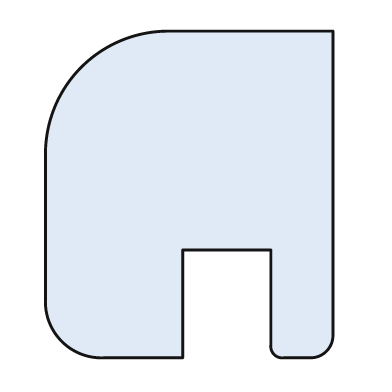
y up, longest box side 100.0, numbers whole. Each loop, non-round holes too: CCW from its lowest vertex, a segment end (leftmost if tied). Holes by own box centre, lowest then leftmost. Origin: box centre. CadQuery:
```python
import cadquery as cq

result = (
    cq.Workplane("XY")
    .moveTo(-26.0, -50.0)
    .lineTo(-2.0, -50.0)
    .lineTo(-2.0, -17.0)
    .lineTo(25.0, -17.0)
    .lineTo(25.0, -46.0)
    .threePointArc((26.0, -49.0), (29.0, -50.0))
    .lineTo(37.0, -50.0)
    .threePointArc((42.0, -48.0), (44.0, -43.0))
    .lineTo(44.0, 50.0)
    .lineTo(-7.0, 50.0)
    .threePointArc((-33.0, 39.0), (-44.0, 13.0))
    .lineTo(-44.0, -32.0)
    .threePointArc((-39.0, -45.0), (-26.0, -50.0))
    .close()
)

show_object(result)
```